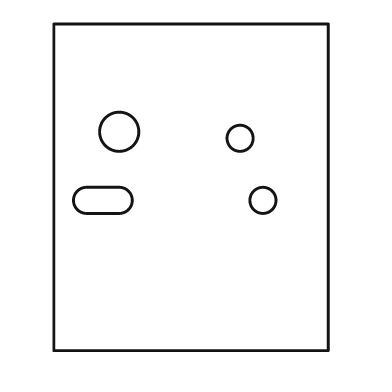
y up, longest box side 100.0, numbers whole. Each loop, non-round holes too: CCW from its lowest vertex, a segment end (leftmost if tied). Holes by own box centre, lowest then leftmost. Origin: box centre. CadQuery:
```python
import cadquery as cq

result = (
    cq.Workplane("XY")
    .moveTo(-42.0, -50.0)
    .lineTo(42.0, -50.0)
    .lineTo(42.0, 50.0)
    .lineTo(-42.0, 50.0)
    .close()
    .moveTo(-32.0, -8.0)
    .lineTo(-22.0, -8.0)
    .threePointArc((-18.0, -4.0), (-22.0, 0.0))
    .lineTo(-32.0, 0.0)
    .threePointArc((-36.0, -4.0), (-32.0, -8.0))
    .close()
    .moveTo(22.0, -4.0)
    .circle(4.0)
    .moveTo(15.0, 15.0)
    .circle(4.0)
    .moveTo(-22.0, 17.0)
    .circle(6.0)
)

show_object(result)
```